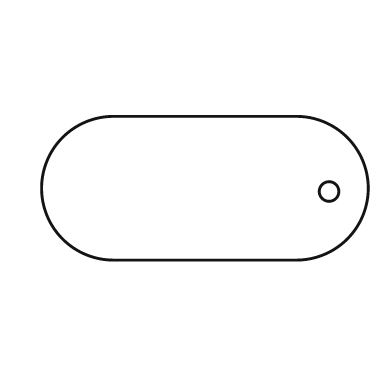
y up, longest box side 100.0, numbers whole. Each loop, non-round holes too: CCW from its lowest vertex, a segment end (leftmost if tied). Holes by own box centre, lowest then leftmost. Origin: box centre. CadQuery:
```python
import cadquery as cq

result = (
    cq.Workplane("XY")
    .moveTo(-28.0, -22.0)
    .lineTo(28.0, -22.0)
    .threePointArc((50.0, 0.0), (28.0, 22.0))
    .lineTo(-28.0, 22.0)
    .threePointArc((-50.0, 0.0), (-28.0, -22.0))
    .close()
    .moveTo(38.0, -1.0)
    .circle(3.0)
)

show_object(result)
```